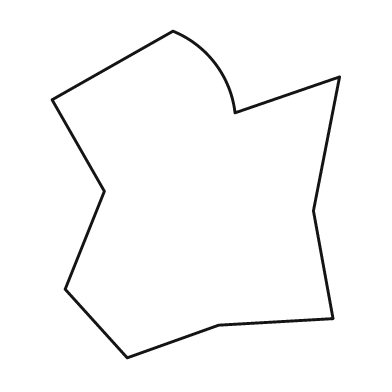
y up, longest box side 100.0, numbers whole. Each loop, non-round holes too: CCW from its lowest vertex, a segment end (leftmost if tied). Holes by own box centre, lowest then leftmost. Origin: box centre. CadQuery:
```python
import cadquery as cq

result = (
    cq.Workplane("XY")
    .moveTo(-21.0, -50.0)
    .lineTo(7.0, -40.0)
    .lineTo(42.0, -38.0)
    .lineTo(36.0, -5.0)
    .lineTo(44.0, 36.0)
    .lineTo(12.0, 25.0)
    .threePointArc((6.0, 40.0), (-7.0, 50.0))
    .lineTo(-44.0, 29.0)
    .lineTo(-28.0, 1.0)
    .lineTo(-40.0, -29.0)
    .close()
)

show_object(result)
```